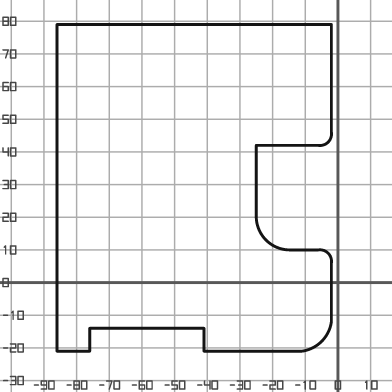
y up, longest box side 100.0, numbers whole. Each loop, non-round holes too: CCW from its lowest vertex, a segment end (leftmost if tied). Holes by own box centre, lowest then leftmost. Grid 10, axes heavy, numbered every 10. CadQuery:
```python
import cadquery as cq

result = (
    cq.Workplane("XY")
    .moveTo(-86.0, -21.0)
    .lineTo(-76.0, -21.0)
    .lineTo(-76.0, -14.0)
    .lineTo(-41.0, -14.0)
    .lineTo(-41.0, -21.0)
    .lineTo(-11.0, -21.0)
    .threePointArc((-5.0, -18.0), (-2.0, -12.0))
    .lineTo(-2.0, 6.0)
    .threePointArc((-3.0, 9.0), (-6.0, 10.0))
    .lineTo(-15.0, 10.0)
    .threePointArc((-22.0, 13.0), (-25.0, 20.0))
    .lineTo(-25.0, 42.0)
    .lineTo(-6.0, 42.0)
    .threePointArc((-3.0, 43.0), (-2.0, 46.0))
    .lineTo(-2.0, 79.0)
    .lineTo(-86.0, 79.0)
    .close()
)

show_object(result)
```